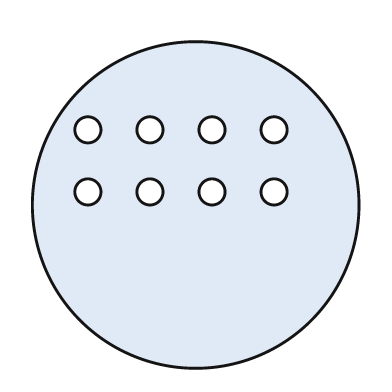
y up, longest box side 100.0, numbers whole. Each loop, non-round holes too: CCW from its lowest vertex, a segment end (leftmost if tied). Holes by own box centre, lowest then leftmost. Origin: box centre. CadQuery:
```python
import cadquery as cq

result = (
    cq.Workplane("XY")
    .moveTo(0.0, 0.0)
    .circle(50.0)
    .moveTo(-33.0, 4.0)
    .circle(4.0)
    .moveTo(-14.0, 4.0)
    .circle(4.0)
    .moveTo(5.0, 4.0)
    .circle(4.0)
    .moveTo(24.0, 4.0)
    .circle(4.0)
    .moveTo(-33.0, 23.0)
    .circle(4.0)
    .moveTo(-14.0, 23.0)
    .circle(4.0)
    .moveTo(5.0, 23.0)
    .circle(4.0)
    .moveTo(24.0, 23.0)
    .circle(4.0)
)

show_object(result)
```